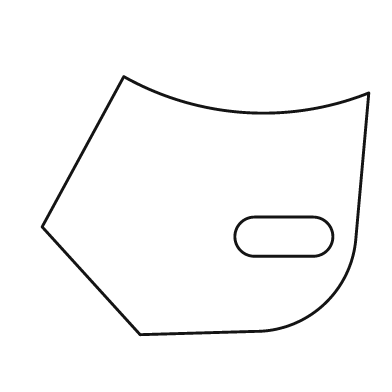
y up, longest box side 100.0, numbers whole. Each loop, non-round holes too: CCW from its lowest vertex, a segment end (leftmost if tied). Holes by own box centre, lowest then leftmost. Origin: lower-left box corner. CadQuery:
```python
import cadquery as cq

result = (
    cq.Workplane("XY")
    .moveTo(30.0, 0.0)
    .lineTo(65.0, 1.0)
    .threePointArc((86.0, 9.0), (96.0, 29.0))
    .lineTo(100.0, 74.0)
    .threePointArc((62.0, 68.0), (25.0, 79.0))
    .lineTo(0.0, 33.0)
    .close()
    .moveTo(65.0, 24.0)
    .lineTo(83.0, 24.0)
    .threePointArc((89.0, 30.0), (83.0, 36.0))
    .lineTo(65.0, 36.0)
    .threePointArc((59.0, 30.0), (65.0, 24.0))
    .close()
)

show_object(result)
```